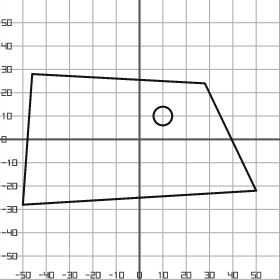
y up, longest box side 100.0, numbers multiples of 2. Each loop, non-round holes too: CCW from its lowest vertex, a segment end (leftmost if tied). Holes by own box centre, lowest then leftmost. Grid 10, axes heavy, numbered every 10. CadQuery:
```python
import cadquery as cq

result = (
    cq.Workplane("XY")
    .moveTo(-50.0, -28.0)
    .lineTo(50.0, -22.0)
    .lineTo(28.0, 24.0)
    .lineTo(-46.0, 28.0)
    .close()
    .moveTo(10.0, 10.0)
    .circle(4.0)
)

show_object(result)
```